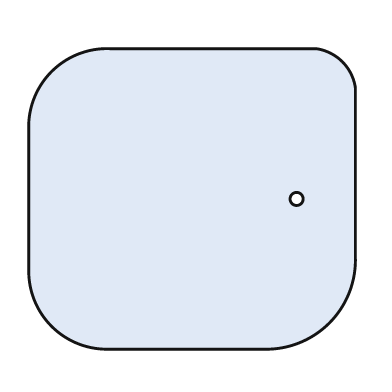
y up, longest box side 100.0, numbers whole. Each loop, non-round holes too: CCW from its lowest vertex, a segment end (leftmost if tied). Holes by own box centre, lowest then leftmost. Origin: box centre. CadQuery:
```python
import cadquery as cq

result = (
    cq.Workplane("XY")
    .moveTo(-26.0, -46.0)
    .lineTo(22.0, -46.0)
    .threePointArc((42.0, -38.0), (50.0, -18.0))
    .lineTo(50.0, 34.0)
    .threePointArc((46.0, 42.0), (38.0, 46.0))
    .lineTo(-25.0, 46.0)
    .threePointArc((-43.0, 39.0), (-50.0, 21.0))
    .lineTo(-50.0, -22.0)
    .threePointArc((-43.0, -39.0), (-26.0, -46.0))
    .close()
    .moveTo(32.0, 0.0)
    .circle(2.0)
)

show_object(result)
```